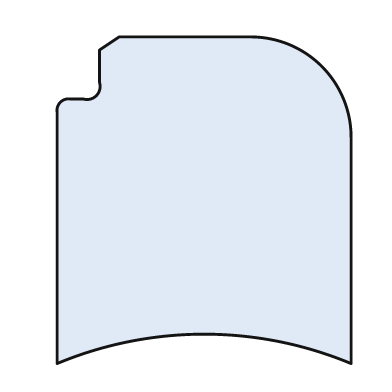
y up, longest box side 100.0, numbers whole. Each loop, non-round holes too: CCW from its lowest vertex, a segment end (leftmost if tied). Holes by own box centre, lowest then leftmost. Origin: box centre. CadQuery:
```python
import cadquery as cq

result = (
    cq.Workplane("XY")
    .moveTo(-45.0, -50.0)
    .threePointArc((0.0, -41.0), (45.0, -50.0))
    .lineTo(45.0, 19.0)
    .threePointArc((36.0, 41.0), (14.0, 50.0))
    .lineTo(-26.0, 50.0)
    .lineTo(-32.0, 46.0)
    .lineTo(-32.0, 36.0)
    .threePointArc((-33.0, 32.0), (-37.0, 31.0))
    .lineTo(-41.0, 31.0)
    .threePointArc((-44.0, 30.0), (-45.0, 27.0))
    .close()
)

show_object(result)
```